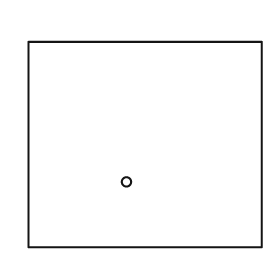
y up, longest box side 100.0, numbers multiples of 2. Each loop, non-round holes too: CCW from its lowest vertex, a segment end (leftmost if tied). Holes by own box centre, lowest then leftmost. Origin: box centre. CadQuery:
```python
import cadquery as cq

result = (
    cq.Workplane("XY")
    .moveTo(-50.0, -44.0)
    .lineTo(50.0, -44.0)
    .lineTo(50.0, 44.0)
    .lineTo(-50.0, 44.0)
    .close()
    .moveTo(-8.0, -16.0)
    .circle(2.0)
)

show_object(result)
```